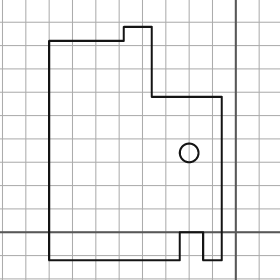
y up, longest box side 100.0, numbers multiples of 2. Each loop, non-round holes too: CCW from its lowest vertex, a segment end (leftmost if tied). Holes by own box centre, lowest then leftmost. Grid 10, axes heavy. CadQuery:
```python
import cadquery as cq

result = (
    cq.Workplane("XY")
    .moveTo(-80.0, -12.0)
    .lineTo(-24.0, -12.0)
    .lineTo(-24.0, 0.0)
    .lineTo(-14.0, 0.0)
    .lineTo(-14.0, -12.0)
    .lineTo(-6.0, -12.0)
    .lineTo(-6.0, 58.0)
    .lineTo(-36.0, 58.0)
    .lineTo(-36.0, 88.0)
    .lineTo(-48.0, 88.0)
    .lineTo(-48.0, 82.0)
    .lineTo(-80.0, 82.0)
    .close()
    .moveTo(-20.0, 34.0)
    .circle(4.0)
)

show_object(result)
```